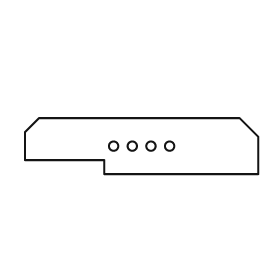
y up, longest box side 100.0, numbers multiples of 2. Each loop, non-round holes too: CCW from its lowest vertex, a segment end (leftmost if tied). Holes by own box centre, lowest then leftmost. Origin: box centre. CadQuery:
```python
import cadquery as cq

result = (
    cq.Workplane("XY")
    .moveTo(-16.0, -12.0)
    .lineTo(50.0, -12.0)
    .lineTo(50.0, 4.0)
    .lineTo(42.0, 12.0)
    .lineTo(-44.0, 12.0)
    .lineTo(-50.0, 6.0)
    .lineTo(-50.0, -6.0)
    .lineTo(-16.0, -6.0)
    .close()
    .moveTo(-12.0, 0.0)
    .circle(2.0)
    .moveTo(-4.0, 0.0)
    .circle(2.0)
    .moveTo(4.0, 0.0)
    .circle(2.0)
    .moveTo(12.0, 0.0)
    .circle(2.0)
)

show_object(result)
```